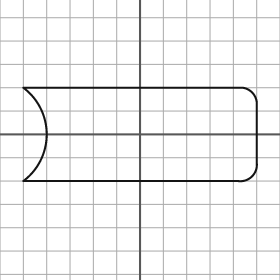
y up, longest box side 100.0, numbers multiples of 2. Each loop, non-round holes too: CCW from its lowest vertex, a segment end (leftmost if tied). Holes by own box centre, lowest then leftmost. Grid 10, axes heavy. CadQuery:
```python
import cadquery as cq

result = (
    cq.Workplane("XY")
    .moveTo(-50.0, -20.0)
    .lineTo(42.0, -20.0)
    .threePointArc((48.0, -18.0), (50.0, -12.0))
    .lineTo(50.0, 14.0)
    .threePointArc((48.0, 18.0), (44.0, 20.0))
    .lineTo(-50.0, 20.0)
    .threePointArc((-40.0, 0.0), (-50.0, -20.0))
    .close()
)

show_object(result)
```